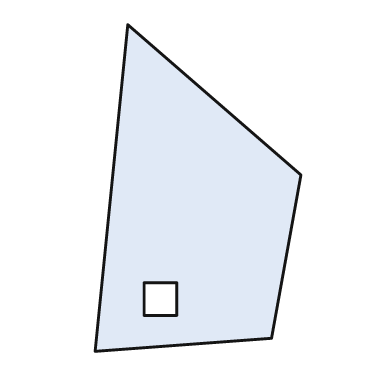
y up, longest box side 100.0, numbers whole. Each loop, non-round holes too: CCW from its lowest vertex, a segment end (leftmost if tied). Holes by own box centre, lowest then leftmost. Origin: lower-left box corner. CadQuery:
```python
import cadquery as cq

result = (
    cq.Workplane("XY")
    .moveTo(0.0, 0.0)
    .lineTo(54.0, 4.0)
    .lineTo(63.0, 54.0)
    .lineTo(10.0, 100.0)
    .close()
    .moveTo(15.0, 11.0)
    .lineTo(25.0, 11.0)
    .lineTo(25.0, 21.0)
    .lineTo(15.0, 21.0)
    .close()
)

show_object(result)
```